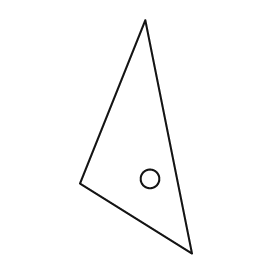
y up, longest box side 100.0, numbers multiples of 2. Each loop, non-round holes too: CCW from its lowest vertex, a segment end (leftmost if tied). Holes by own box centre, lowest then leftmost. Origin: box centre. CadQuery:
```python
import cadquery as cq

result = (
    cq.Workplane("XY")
    .moveTo(24.0, -50.0)
    .lineTo(4.0, 50.0)
    .lineTo(-24.0, -20.0)
    .close()
    .moveTo(6.0, -18.0)
    .circle(4.0)
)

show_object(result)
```